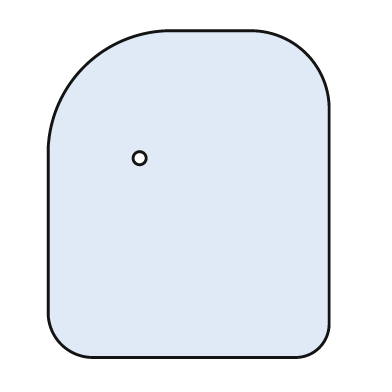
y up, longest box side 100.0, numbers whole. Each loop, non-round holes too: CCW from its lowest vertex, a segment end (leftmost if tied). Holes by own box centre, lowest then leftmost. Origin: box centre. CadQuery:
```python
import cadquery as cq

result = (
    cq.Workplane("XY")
    .moveTo(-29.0, -50.0)
    .lineTo(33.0, -50.0)
    .threePointArc((40.0, -47.0), (43.0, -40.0))
    .lineTo(43.0, 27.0)
    .threePointArc((36.0, 43.0), (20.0, 50.0))
    .lineTo(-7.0, 50.0)
    .threePointArc((-32.0, 39.0), (-43.0, 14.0))
    .lineTo(-43.0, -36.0)
    .threePointArc((-39.0, -46.0), (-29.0, -50.0))
    .close()
    .moveTo(-15.0, 11.0)
    .circle(2.0)
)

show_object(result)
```